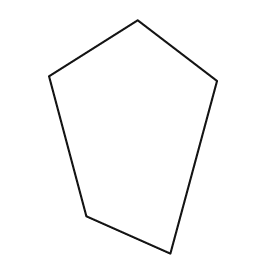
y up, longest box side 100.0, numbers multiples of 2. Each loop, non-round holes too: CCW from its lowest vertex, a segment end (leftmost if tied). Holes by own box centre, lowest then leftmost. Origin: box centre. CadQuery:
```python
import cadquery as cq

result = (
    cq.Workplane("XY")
    .moveTo(16.0, -50.0)
    .lineTo(36.0, 24.0)
    .lineTo(2.0, 50.0)
    .lineTo(-36.0, 26.0)
    .lineTo(-20.0, -34.0)
    .close()
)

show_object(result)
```